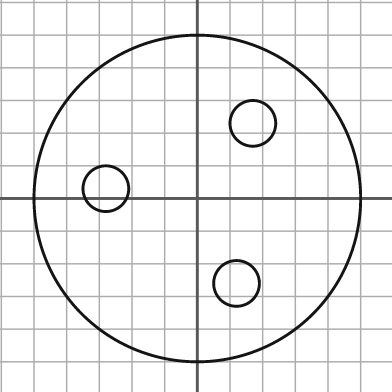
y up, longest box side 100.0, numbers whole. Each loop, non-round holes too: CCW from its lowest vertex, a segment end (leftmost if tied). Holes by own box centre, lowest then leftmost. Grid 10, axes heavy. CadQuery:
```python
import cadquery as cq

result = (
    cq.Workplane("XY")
    .moveTo(0.0, 0.0)
    .circle(50.0)
    .moveTo(12.0, -26.0)
    .circle(7.0)
    .moveTo(-28.0, 3.0)
    .circle(7.0)
    .moveTo(17.0, 23.0)
    .circle(7.0)
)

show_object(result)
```